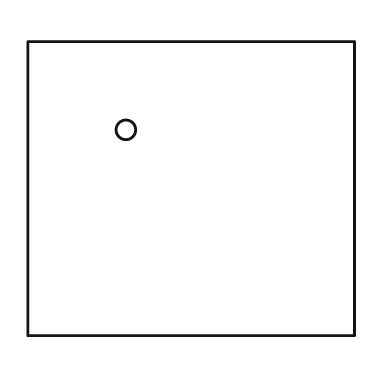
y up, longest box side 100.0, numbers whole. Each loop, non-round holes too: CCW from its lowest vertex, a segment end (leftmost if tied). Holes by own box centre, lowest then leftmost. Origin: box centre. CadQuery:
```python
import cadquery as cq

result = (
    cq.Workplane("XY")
    .moveTo(-50.0, -45.0)
    .lineTo(50.0, -45.0)
    .lineTo(50.0, 45.0)
    .lineTo(-50.0, 45.0)
    .close()
    .moveTo(-20.0, 18.0)
    .circle(3.0)
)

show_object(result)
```